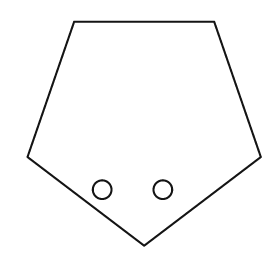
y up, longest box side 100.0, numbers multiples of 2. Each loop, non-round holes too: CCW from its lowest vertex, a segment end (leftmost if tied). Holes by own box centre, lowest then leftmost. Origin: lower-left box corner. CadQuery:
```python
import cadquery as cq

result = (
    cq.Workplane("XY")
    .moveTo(50.0, 0.0)
    .lineTo(100.0, 38.0)
    .lineTo(80.0, 96.0)
    .lineTo(20.0, 96.0)
    .lineTo(0.0, 38.0)
    .close()
    .moveTo(32.0, 24.0)
    .circle(4.0)
    .moveTo(58.0, 24.0)
    .circle(4.0)
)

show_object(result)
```